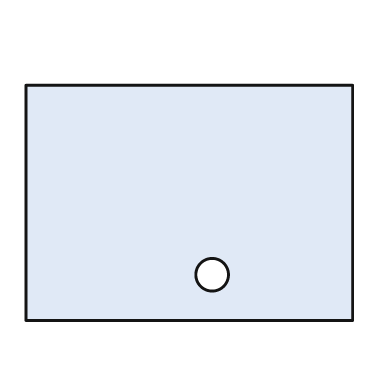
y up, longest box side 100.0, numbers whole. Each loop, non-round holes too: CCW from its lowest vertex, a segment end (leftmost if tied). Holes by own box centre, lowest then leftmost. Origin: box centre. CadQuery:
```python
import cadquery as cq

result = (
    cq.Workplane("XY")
    .moveTo(-50.0, -36.0)
    .lineTo(50.0, -36.0)
    .lineTo(50.0, 36.0)
    .lineTo(-50.0, 36.0)
    .close()
    .moveTo(7.0, -22.0)
    .circle(5.0)
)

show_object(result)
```